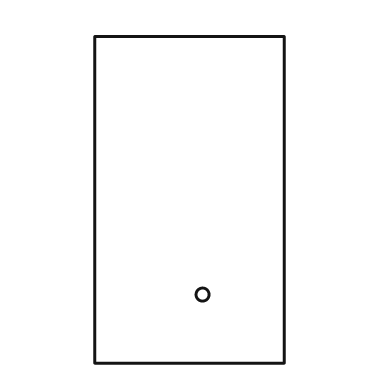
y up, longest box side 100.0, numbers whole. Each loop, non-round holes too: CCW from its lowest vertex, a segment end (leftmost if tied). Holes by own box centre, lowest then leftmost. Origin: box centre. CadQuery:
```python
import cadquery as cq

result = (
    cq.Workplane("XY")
    .moveTo(-29.0, -50.0)
    .lineTo(29.0, -50.0)
    .lineTo(29.0, 50.0)
    .lineTo(-29.0, 50.0)
    .close()
    .moveTo(4.0, -29.0)
    .circle(2.0)
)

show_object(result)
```